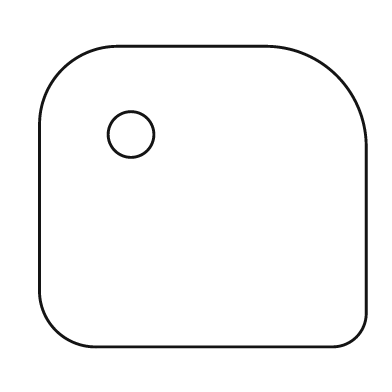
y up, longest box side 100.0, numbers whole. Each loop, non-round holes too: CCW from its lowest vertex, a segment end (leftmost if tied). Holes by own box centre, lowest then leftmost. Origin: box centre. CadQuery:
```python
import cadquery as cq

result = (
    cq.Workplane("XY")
    .moveTo(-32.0, -46.0)
    .lineTo(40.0, -46.0)
    .threePointArc((47.0, -43.0), (50.0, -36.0))
    .lineTo(50.0, 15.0)
    .threePointArc((41.0, 37.0), (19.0, 46.0))
    .lineTo(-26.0, 46.0)
    .threePointArc((-43.0, 39.0), (-50.0, 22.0))
    .lineTo(-50.0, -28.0)
    .threePointArc((-45.0, -41.0), (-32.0, -46.0))
    .close()
    .moveTo(-22.0, 19.0)
    .circle(7.0)
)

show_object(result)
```